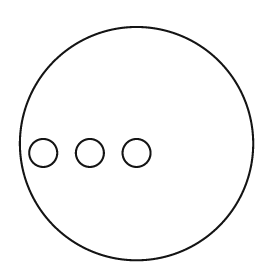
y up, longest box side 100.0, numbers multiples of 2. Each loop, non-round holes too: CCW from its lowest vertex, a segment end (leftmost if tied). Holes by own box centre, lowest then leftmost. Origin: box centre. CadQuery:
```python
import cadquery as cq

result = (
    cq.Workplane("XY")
    .moveTo(0.0, 0.0)
    .circle(50.0)
    .moveTo(-40.0, -4.0)
    .circle(6.0)
    .moveTo(-20.0, -4.0)
    .circle(6.0)
    .moveTo(0.0, -4.0)
    .circle(6.0)
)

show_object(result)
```